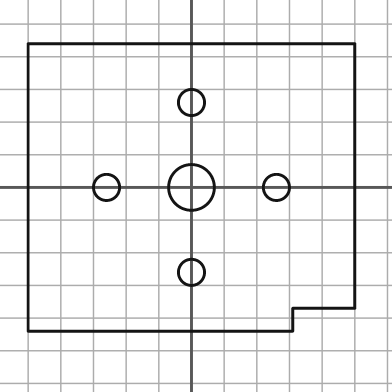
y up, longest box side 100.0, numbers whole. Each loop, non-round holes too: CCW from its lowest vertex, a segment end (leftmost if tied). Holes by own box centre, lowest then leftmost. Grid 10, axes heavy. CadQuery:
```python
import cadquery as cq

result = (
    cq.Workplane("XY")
    .moveTo(-50.0, -44.0)
    .lineTo(31.0, -44.0)
    .lineTo(31.0, -37.0)
    .lineTo(50.0, -37.0)
    .lineTo(50.0, 44.0)
    .lineTo(-50.0, 44.0)
    .close()
    .moveTo(0.0, -26.0)
    .circle(4.0)
    .moveTo(-26.0, 0.0)
    .circle(4.0)
    .moveTo(0.0, 0.0)
    .circle(7.0)
    .moveTo(26.0, 0.0)
    .circle(4.0)
    .moveTo(0.0, 26.0)
    .circle(4.0)
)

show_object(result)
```